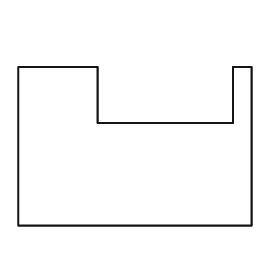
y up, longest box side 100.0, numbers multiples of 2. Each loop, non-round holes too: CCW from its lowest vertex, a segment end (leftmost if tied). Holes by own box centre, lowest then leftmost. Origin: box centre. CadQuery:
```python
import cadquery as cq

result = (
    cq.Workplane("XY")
    .moveTo(-50.0, -34.0)
    .lineTo(50.0, -34.0)
    .lineTo(50.0, 34.0)
    .lineTo(42.0, 34.0)
    .lineTo(42.0, 10.0)
    .lineTo(-16.0, 10.0)
    .lineTo(-16.0, 34.0)
    .lineTo(-50.0, 34.0)
    .close()
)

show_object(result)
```